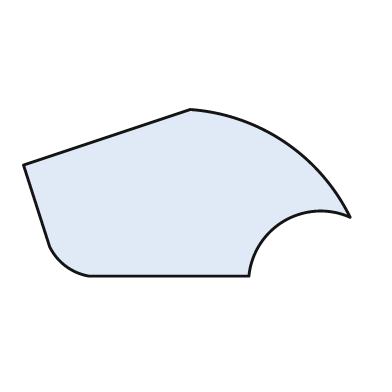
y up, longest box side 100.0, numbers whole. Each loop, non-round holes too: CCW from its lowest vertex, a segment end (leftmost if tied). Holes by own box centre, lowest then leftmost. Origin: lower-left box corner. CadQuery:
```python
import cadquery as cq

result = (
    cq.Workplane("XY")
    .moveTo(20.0, 0.0)
    .lineTo(69.0, 0.0)
    .threePointArc((80.0, 17.0), (100.0, 18.0))
    .threePointArc((80.0, 41.0), (51.0, 51.0))
    .lineTo(0.0, 34.0)
    .lineTo(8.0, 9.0)
    .threePointArc((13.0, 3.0), (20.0, 0.0))
    .close()
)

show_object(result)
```